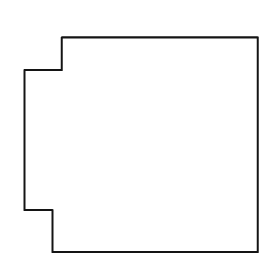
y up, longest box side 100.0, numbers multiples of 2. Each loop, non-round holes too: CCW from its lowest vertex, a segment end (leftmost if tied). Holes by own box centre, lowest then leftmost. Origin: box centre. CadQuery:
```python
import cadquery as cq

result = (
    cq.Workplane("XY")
    .moveTo(-38.0, -46.0)
    .lineTo(50.0, -46.0)
    .lineTo(50.0, 46.0)
    .lineTo(-34.0, 46.0)
    .lineTo(-34.0, 32.0)
    .lineTo(-50.0, 32.0)
    .lineTo(-50.0, -28.0)
    .lineTo(-38.0, -28.0)
    .close()
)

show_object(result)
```